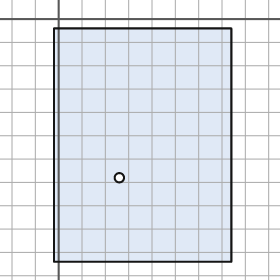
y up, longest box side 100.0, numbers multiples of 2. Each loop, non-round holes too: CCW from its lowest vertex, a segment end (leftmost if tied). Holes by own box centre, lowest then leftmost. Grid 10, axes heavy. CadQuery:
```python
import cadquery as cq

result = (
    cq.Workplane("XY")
    .moveTo(-2.0, -104.0)
    .lineTo(74.0, -104.0)
    .lineTo(74.0, -4.0)
    .lineTo(-2.0, -4.0)
    .close()
    .moveTo(26.0, -68.0)
    .circle(2.0)
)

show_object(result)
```